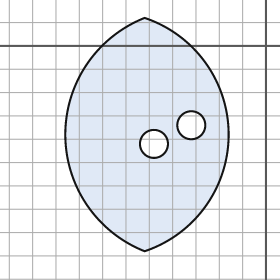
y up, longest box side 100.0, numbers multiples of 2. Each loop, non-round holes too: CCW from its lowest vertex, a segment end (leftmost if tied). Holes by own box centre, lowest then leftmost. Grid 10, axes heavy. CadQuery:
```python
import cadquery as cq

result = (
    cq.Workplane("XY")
    .moveTo(-52.0, -88.0)
    .threePointArc((-16.0, -38.0), (-52.0, 12.0))
    .threePointArc((-86.0, -38.0), (-52.0, -88.0))
    .close()
    .moveTo(-48.0, -42.0)
    .circle(6.0)
    .moveTo(-32.0, -34.0)
    .circle(6.0)
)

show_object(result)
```